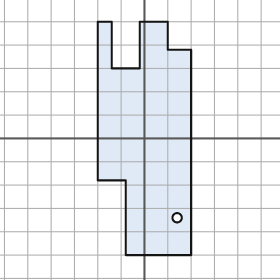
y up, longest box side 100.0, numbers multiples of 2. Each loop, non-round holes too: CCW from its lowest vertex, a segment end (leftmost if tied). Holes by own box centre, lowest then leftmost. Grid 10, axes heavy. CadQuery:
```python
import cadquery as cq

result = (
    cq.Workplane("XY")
    .moveTo(-8.0, -50.0)
    .lineTo(20.0, -50.0)
    .lineTo(20.0, 38.0)
    .lineTo(10.0, 38.0)
    .lineTo(10.0, 50.0)
    .lineTo(-2.0, 50.0)
    .lineTo(-2.0, 30.0)
    .lineTo(-14.0, 30.0)
    .lineTo(-14.0, 50.0)
    .lineTo(-20.0, 50.0)
    .lineTo(-20.0, -18.0)
    .lineTo(-8.0, -18.0)
    .close()
    .moveTo(14.0, -34.0)
    .circle(2.0)
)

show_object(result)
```